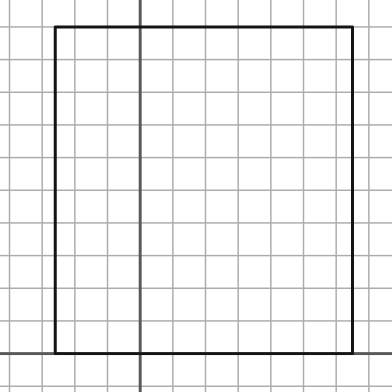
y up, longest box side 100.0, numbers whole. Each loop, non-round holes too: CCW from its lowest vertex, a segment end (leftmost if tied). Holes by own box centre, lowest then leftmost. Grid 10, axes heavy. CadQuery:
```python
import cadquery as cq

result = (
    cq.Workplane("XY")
    .moveTo(-26.0, 0.0)
    .lineTo(65.0, 0.0)
    .lineTo(65.0, 100.0)
    .lineTo(-26.0, 100.0)
    .close()
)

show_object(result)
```